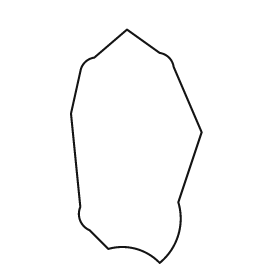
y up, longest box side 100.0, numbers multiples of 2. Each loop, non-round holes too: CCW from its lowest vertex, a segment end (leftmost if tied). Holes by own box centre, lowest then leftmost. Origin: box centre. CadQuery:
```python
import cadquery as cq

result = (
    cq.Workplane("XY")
    .moveTo(10.0, -50.0)
    .threePointArc((18.0, -38.0), (18.0, -24.0))
    .lineTo(28.0, 6.0)
    .lineTo(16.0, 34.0)
    .threePointArc((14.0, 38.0), (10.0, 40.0))
    .lineTo(-4.0, 50.0)
    .lineTo(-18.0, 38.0)
    .threePointArc((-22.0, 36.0), (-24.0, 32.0))
    .lineTo(-28.0, 14.0)
    .lineTo(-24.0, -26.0)
    .threePointArc((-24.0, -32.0), (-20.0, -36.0))
    .lineTo(-12.0, -44.0)
    .threePointArc((0.0, -44.0), (10.0, -50.0))
    .close()
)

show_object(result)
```